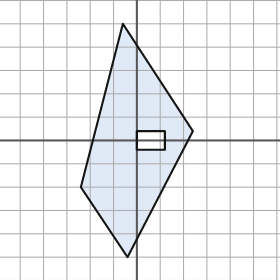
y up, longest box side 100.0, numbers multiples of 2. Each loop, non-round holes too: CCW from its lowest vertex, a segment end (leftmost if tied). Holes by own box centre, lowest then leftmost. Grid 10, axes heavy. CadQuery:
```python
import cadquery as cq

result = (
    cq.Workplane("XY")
    .moveTo(-4.0, -50.0)
    .lineTo(24.0, 4.0)
    .lineTo(-6.0, 50.0)
    .lineTo(-24.0, -20.0)
    .close()
    .moveTo(0.0, -4.0)
    .lineTo(12.0, -4.0)
    .lineTo(12.0, 4.0)
    .lineTo(0.0, 4.0)
    .close()
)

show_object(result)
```